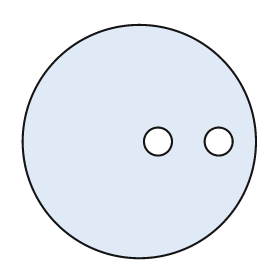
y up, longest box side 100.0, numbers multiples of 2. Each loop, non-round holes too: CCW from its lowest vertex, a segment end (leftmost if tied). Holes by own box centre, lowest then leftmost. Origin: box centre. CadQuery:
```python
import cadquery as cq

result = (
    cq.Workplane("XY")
    .moveTo(0.0, 0.0)
    .circle(50.0)
    .moveTo(8.0, 0.0)
    .circle(6.0)
    .moveTo(34.0, 0.0)
    .circle(6.0)
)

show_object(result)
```